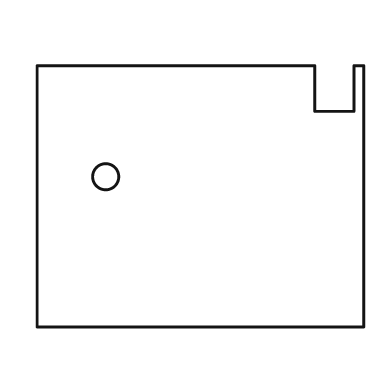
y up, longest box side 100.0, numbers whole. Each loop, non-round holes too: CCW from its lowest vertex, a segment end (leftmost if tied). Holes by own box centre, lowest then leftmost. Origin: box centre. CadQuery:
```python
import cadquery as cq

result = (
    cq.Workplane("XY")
    .moveTo(-50.0, -40.0)
    .lineTo(50.0, -40.0)
    .lineTo(50.0, 40.0)
    .lineTo(47.0, 40.0)
    .lineTo(47.0, 26.0)
    .lineTo(35.0, 26.0)
    .lineTo(35.0, 40.0)
    .lineTo(-50.0, 40.0)
    .close()
    .moveTo(-29.0, 6.0)
    .circle(4.0)
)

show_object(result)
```